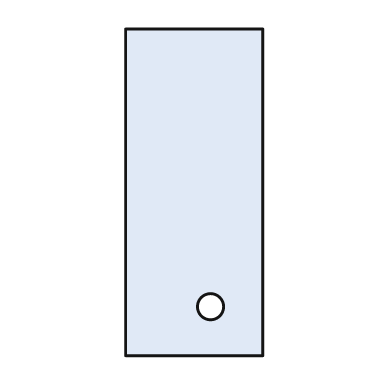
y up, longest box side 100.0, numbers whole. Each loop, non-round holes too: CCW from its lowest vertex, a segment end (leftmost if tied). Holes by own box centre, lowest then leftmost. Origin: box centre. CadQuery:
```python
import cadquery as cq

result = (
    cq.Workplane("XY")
    .moveTo(-21.0, -50.0)
    .lineTo(21.0, -50.0)
    .lineTo(21.0, 50.0)
    .lineTo(-21.0, 50.0)
    .close()
    .moveTo(5.0, -35.0)
    .circle(4.0)
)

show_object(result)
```